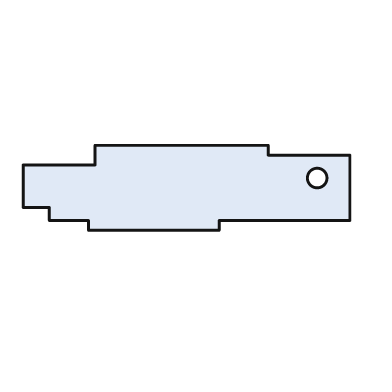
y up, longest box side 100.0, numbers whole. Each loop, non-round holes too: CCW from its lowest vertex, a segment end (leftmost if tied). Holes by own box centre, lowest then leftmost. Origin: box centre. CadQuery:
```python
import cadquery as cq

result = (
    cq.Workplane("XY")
    .moveTo(-30.0, -13.0)
    .lineTo(10.0, -13.0)
    .lineTo(10.0, -10.0)
    .lineTo(50.0, -10.0)
    .lineTo(50.0, 10.0)
    .lineTo(25.0, 10.0)
    .lineTo(25.0, 13.0)
    .lineTo(-28.0, 13.0)
    .lineTo(-28.0, 7.0)
    .lineTo(-50.0, 7.0)
    .lineTo(-50.0, -6.0)
    .lineTo(-42.0, -6.0)
    .lineTo(-42.0, -10.0)
    .lineTo(-30.0, -10.0)
    .close()
    .moveTo(40.0, 3.0)
    .circle(3.0)
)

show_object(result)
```